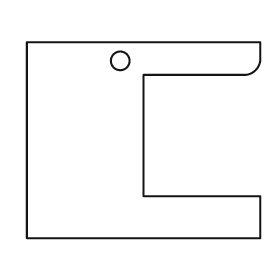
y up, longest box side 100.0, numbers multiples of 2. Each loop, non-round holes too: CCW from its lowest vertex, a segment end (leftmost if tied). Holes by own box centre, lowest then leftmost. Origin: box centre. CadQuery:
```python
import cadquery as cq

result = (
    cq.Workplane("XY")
    .moveTo(-50.0, -42.0)
    .lineTo(50.0, -42.0)
    .lineTo(50.0, -24.0)
    .lineTo(0.0, -24.0)
    .lineTo(0.0, 28.0)
    .lineTo(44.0, 28.0)
    .threePointArc((48.0, 30.0), (50.0, 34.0))
    .lineTo(50.0, 42.0)
    .lineTo(-50.0, 42.0)
    .close()
    .moveTo(-10.0, 34.0)
    .circle(4.0)
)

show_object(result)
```